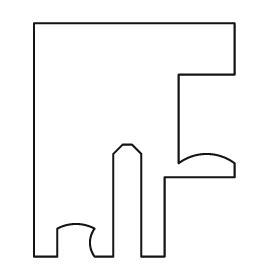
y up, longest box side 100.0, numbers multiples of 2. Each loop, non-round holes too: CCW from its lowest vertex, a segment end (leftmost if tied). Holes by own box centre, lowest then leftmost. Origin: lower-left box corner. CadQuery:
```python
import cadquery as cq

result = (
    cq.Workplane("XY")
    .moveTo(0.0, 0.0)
    .lineTo(10.0, 0.0)
    .lineTo(10.0, 12.0)
    .threePointArc((18.0, 14.0), (26.0, 12.0))
    .threePointArc((24.0, 6.0), (26.0, 0.0))
    .lineTo(34.0, 0.0)
    .lineTo(34.0, 44.0)
    .lineTo(38.0, 48.0)
    .lineTo(42.0, 48.0)
    .lineTo(46.0, 44.0)
    .lineTo(46.0, 0.0)
    .lineTo(56.0, 0.0)
    .lineTo(56.0, 34.0)
    .lineTo(86.0, 34.0)
    .lineTo(86.0, 40.0)
    .threePointArc((74.0, 44.0), (62.0, 40.0))
    .lineTo(62.0, 78.0)
    .lineTo(86.0, 78.0)
    .lineTo(86.0, 100.0)
    .lineTo(0.0, 100.0)
    .close()
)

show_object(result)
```